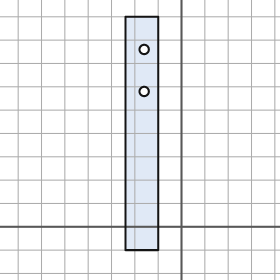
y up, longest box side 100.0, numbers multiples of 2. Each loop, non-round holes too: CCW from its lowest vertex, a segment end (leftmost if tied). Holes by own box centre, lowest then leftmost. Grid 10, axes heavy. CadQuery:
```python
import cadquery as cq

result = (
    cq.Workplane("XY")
    .moveTo(-24.0, -10.0)
    .lineTo(-10.0, -10.0)
    .lineTo(-10.0, 90.0)
    .lineTo(-24.0, 90.0)
    .close()
    .moveTo(-16.0, 58.0)
    .circle(2.0)
    .moveTo(-16.0, 76.0)
    .circle(2.0)
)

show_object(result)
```